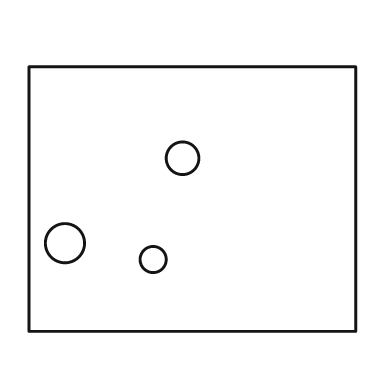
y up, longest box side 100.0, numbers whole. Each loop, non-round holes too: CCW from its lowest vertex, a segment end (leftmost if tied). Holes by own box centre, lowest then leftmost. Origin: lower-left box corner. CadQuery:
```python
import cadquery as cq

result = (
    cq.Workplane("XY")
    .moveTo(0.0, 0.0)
    .lineTo(100.0, 0.0)
    .lineTo(100.0, 81.0)
    .lineTo(0.0, 81.0)
    .close()
    .moveTo(38.0, 22.0)
    .circle(4.0)
    .moveTo(11.0, 27.0)
    .circle(6.0)
    .moveTo(47.0, 53.0)
    .circle(5.0)
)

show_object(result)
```